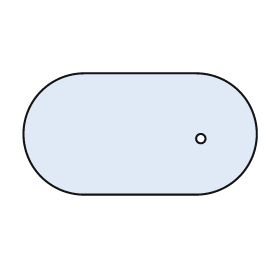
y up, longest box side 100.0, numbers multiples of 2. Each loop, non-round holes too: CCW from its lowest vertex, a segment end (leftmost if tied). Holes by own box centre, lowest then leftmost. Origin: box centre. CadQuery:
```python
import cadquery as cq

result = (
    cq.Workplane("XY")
    .moveTo(-24.0, -26.0)
    .lineTo(24.0, -26.0)
    .threePointArc((50.0, 0.0), (24.0, 26.0))
    .lineTo(-24.0, 26.0)
    .threePointArc((-50.0, 0.0), (-24.0, -26.0))
    .close()
    .moveTo(26.0, -2.0)
    .circle(2.0)
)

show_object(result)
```